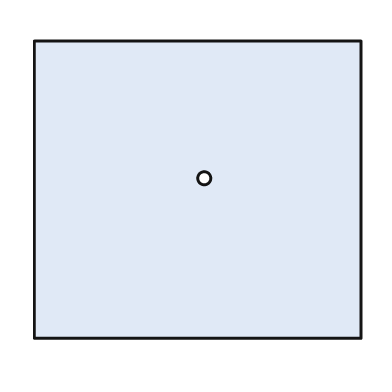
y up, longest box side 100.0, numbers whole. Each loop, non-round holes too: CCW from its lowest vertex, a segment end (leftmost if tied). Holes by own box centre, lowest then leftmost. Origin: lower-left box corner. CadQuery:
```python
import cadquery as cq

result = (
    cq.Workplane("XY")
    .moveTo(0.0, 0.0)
    .lineTo(100.0, 0.0)
    .lineTo(100.0, 91.0)
    .lineTo(0.0, 91.0)
    .close()
    .moveTo(52.0, 49.0)
    .circle(2.0)
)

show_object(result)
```